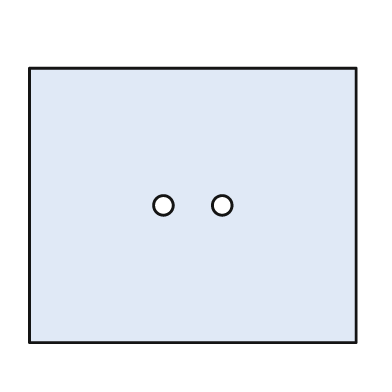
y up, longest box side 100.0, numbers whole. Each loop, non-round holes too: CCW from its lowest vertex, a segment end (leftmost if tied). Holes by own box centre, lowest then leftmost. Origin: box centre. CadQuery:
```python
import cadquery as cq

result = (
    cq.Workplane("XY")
    .moveTo(-50.0, -42.0)
    .lineTo(50.0, -42.0)
    .lineTo(50.0, 42.0)
    .lineTo(-50.0, 42.0)
    .close()
    .moveTo(-9.0, 0.0)
    .circle(3.0)
    .moveTo(9.0, 0.0)
    .circle(3.0)
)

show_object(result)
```